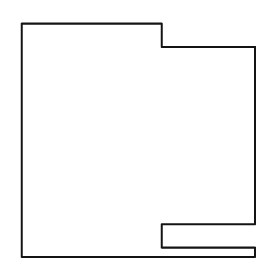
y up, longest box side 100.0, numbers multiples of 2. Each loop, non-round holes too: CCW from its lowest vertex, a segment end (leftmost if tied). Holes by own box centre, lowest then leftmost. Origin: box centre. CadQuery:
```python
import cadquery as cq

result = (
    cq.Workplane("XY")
    .moveTo(-50.0, -50.0)
    .lineTo(50.0, -50.0)
    .lineTo(50.0, -46.0)
    .lineTo(10.0, -46.0)
    .lineTo(10.0, -36.0)
    .lineTo(50.0, -36.0)
    .lineTo(50.0, 40.0)
    .lineTo(10.0, 40.0)
    .lineTo(10.0, 50.0)
    .lineTo(-50.0, 50.0)
    .close()
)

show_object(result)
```